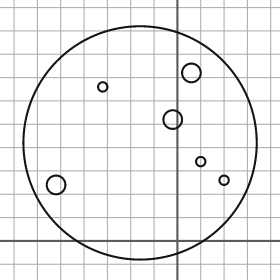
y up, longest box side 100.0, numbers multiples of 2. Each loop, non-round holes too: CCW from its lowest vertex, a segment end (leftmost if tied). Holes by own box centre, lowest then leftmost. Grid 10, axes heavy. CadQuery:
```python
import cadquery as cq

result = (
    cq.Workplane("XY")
    .moveTo(-16.0, 42.0)
    .circle(50.0)
    .moveTo(-52.0, 24.0)
    .circle(4.0)
    .moveTo(20.0, 26.0)
    .circle(2.0)
    .moveTo(10.0, 34.0)
    .circle(2.0)
    .moveTo(-2.0, 52.0)
    .circle(4.0)
    .moveTo(-32.0, 66.0)
    .circle(2.0)
    .moveTo(6.0, 72.0)
    .circle(4.0)
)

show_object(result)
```